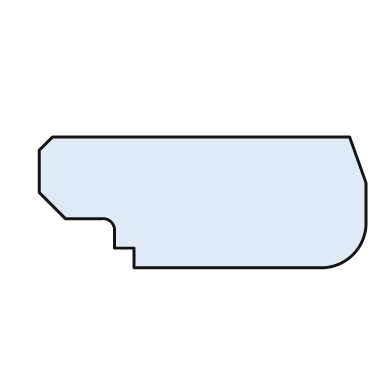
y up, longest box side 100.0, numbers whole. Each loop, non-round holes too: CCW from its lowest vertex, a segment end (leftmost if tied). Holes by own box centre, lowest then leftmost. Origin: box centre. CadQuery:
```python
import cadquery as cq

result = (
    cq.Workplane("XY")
    .moveTo(-21.0, -20.0)
    .lineTo(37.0, -20.0)
    .threePointArc((46.0, -16.0), (50.0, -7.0))
    .lineTo(50.0, 6.0)
    .lineTo(45.0, 20.0)
    .lineTo(-46.0, 20.0)
    .lineTo(-50.0, 16.0)
    .lineTo(-50.0, 3.0)
    .lineTo(-42.0, -5.0)
    .lineTo(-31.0, -5.0)
    .threePointArc((-28.0, -6.0), (-27.0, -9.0))
    .lineTo(-27.0, -14.0)
    .lineTo(-21.0, -14.0)
    .close()
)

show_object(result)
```